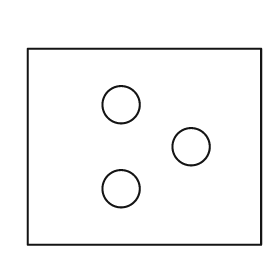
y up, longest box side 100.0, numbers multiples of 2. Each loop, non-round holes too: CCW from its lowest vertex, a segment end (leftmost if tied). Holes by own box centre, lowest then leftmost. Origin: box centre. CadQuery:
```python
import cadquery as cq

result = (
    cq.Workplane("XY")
    .moveTo(-50.0, -42.0)
    .lineTo(50.0, -42.0)
    .lineTo(50.0, 42.0)
    .lineTo(-50.0, 42.0)
    .close()
    .moveTo(-10.0, -18.0)
    .circle(8.0)
    .moveTo(20.0, 0.0)
    .circle(8.0)
    .moveTo(-10.0, 18.0)
    .circle(8.0)
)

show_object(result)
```